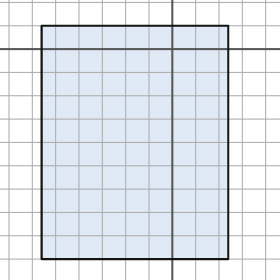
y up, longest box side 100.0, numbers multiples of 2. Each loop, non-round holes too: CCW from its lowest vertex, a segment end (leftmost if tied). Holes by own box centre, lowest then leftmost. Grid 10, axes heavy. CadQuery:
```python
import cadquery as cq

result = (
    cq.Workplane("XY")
    .moveTo(-56.0, -90.0)
    .lineTo(24.0, -90.0)
    .lineTo(24.0, 10.0)
    .lineTo(-56.0, 10.0)
    .close()
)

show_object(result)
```